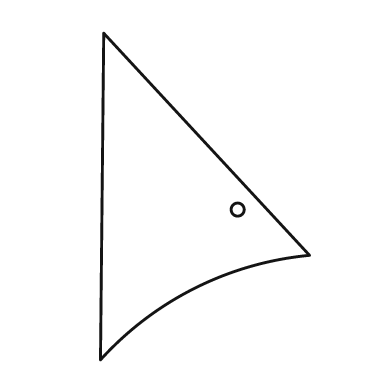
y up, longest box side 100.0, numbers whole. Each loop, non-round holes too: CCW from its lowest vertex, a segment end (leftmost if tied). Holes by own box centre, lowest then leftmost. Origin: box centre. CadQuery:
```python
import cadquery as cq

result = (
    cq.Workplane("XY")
    .moveTo(-32.0, -50.0)
    .threePointArc((-3.0, -28.0), (32.0, -18.0))
    .lineTo(-31.0, 50.0)
    .close()
    .moveTo(10.0, -4.0)
    .circle(2.0)
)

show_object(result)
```